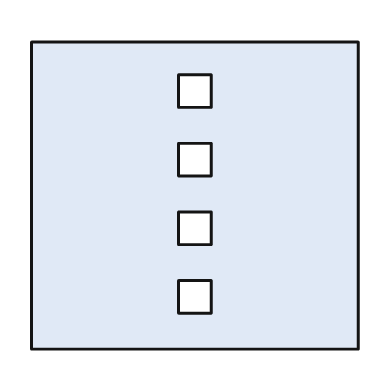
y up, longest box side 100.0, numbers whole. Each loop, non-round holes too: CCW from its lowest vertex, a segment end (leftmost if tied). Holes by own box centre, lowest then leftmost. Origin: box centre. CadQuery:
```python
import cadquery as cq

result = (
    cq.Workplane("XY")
    .moveTo(-50.0, -47.0)
    .lineTo(50.0, -47.0)
    .lineTo(50.0, 47.0)
    .lineTo(-50.0, 47.0)
    .close()
    .moveTo(-5.0, -36.0)
    .lineTo(5.0, -36.0)
    .lineTo(5.0, -26.0)
    .lineTo(-5.0, -26.0)
    .close()
    .moveTo(-5.0, -15.0)
    .lineTo(5.0, -15.0)
    .lineTo(5.0, -5.0)
    .lineTo(-5.0, -5.0)
    .close()
    .moveTo(-5.0, 6.0)
    .lineTo(5.0, 6.0)
    .lineTo(5.0, 16.0)
    .lineTo(-5.0, 16.0)
    .close()
    .moveTo(-5.0, 27.0)
    .lineTo(5.0, 27.0)
    .lineTo(5.0, 37.0)
    .lineTo(-5.0, 37.0)
    .close()
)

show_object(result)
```